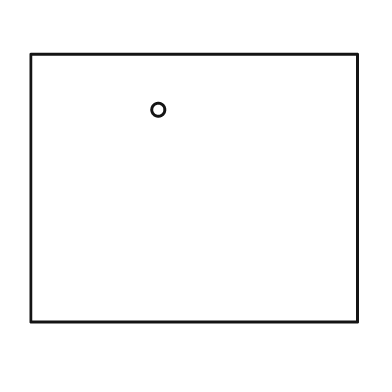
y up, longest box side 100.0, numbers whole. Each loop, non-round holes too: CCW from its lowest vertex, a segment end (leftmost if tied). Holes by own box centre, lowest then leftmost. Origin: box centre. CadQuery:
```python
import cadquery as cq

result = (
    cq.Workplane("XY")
    .moveTo(-50.0, -41.0)
    .lineTo(50.0, -41.0)
    .lineTo(50.0, 41.0)
    .lineTo(-50.0, 41.0)
    .close()
    .moveTo(-11.0, 24.0)
    .circle(2.0)
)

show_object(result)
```